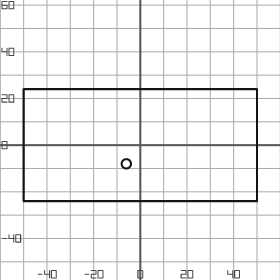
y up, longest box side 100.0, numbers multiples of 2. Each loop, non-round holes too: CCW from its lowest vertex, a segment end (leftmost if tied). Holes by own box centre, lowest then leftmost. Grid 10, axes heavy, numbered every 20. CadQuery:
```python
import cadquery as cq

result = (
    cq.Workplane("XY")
    .moveTo(-50.0, -24.0)
    .lineTo(50.0, -24.0)
    .lineTo(50.0, 24.0)
    .lineTo(-50.0, 24.0)
    .close()
    .moveTo(-6.0, -8.0)
    .circle(2.0)
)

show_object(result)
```